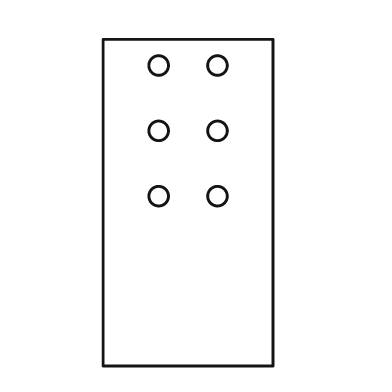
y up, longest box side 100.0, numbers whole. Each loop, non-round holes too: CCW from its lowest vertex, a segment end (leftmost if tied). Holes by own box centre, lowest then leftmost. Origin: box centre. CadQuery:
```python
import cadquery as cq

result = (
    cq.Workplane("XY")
    .moveTo(-26.0, -50.0)
    .lineTo(26.0, -50.0)
    .lineTo(26.0, 50.0)
    .lineTo(-26.0, 50.0)
    .close()
    .moveTo(-9.0, 2.0)
    .circle(3.0)
    .moveTo(9.0, 2.0)
    .circle(3.0)
    .moveTo(-9.0, 22.0)
    .circle(3.0)
    .moveTo(9.0, 22.0)
    .circle(3.0)
    .moveTo(-9.0, 42.0)
    .circle(3.0)
    .moveTo(9.0, 42.0)
    .circle(3.0)
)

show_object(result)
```